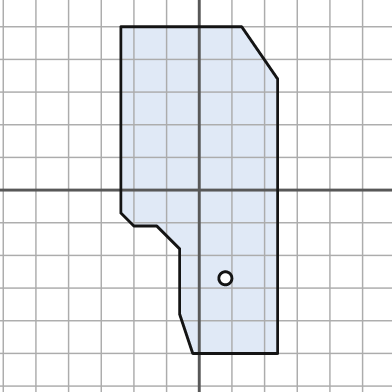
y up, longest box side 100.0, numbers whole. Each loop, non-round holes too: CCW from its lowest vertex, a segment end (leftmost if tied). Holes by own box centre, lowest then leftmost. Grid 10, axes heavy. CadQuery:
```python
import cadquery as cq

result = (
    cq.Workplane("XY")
    .moveTo(-2.0, -50.0)
    .lineTo(24.0, -50.0)
    .lineTo(24.0, 34.0)
    .lineTo(13.0, 50.0)
    .lineTo(-24.0, 50.0)
    .lineTo(-24.0, -7.0)
    .lineTo(-20.0, -11.0)
    .lineTo(-13.0, -11.0)
    .lineTo(-6.0, -18.0)
    .lineTo(-6.0, -38.0)
    .close()
    .moveTo(8.0, -27.0)
    .circle(2.0)
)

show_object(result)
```